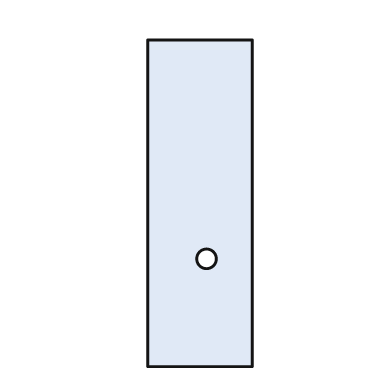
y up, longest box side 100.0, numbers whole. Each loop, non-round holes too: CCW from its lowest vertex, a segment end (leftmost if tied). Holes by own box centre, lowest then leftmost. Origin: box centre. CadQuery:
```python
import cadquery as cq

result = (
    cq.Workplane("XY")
    .moveTo(-16.0, -50.0)
    .lineTo(16.0, -50.0)
    .lineTo(16.0, 50.0)
    .lineTo(-16.0, 50.0)
    .close()
    .moveTo(2.0, -17.0)
    .circle(3.0)
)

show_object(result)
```